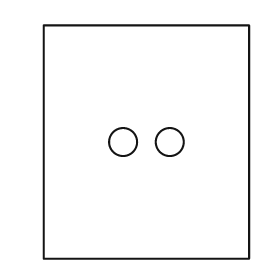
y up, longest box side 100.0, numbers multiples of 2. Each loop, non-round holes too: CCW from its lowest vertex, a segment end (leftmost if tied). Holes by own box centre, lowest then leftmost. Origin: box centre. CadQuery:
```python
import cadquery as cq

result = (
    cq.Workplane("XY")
    .moveTo(-44.0, -50.0)
    .lineTo(44.0, -50.0)
    .lineTo(44.0, 50.0)
    .lineTo(-44.0, 50.0)
    .close()
    .moveTo(-10.0, 0.0)
    .circle(6.0)
    .moveTo(10.0, 0.0)
    .circle(6.0)
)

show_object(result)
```